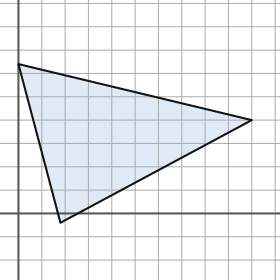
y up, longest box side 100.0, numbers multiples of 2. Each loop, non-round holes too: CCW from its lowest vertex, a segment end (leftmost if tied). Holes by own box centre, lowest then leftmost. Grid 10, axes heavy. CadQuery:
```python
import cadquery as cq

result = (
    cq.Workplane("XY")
    .moveTo(18.0, -4.0)
    .lineTo(100.0, 40.0)
    .lineTo(0.0, 64.0)
    .close()
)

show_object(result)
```